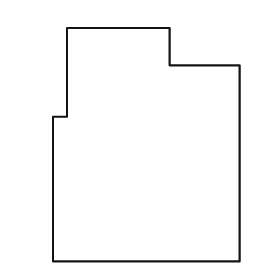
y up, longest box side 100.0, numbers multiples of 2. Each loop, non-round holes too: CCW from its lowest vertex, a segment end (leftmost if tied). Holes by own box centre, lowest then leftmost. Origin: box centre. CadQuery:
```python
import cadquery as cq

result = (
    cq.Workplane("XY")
    .moveTo(-40.0, -50.0)
    .lineTo(40.0, -50.0)
    .lineTo(40.0, 34.0)
    .lineTo(10.0, 34.0)
    .lineTo(10.0, 50.0)
    .lineTo(-34.0, 50.0)
    .lineTo(-34.0, 12.0)
    .lineTo(-40.0, 12.0)
    .close()
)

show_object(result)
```